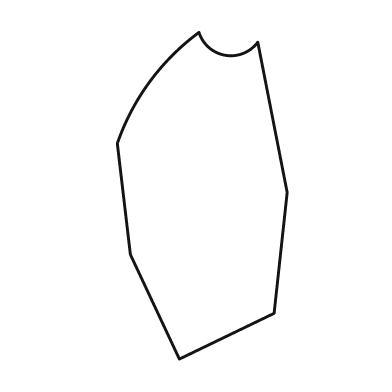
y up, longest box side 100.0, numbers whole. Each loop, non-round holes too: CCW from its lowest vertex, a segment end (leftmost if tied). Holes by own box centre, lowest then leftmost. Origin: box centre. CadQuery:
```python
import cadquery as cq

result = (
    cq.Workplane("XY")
    .moveTo(-7.0, -50.0)
    .lineTo(22.0, -36.0)
    .lineTo(26.0, 1.0)
    .lineTo(17.0, 47.0)
    .threePointArc((7.0, 43.0), (-1.0, 50.0))
    .threePointArc((-16.0, 35.0), (-26.0, 16.0))
    .lineTo(-22.0, -18.0)
    .close()
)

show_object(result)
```